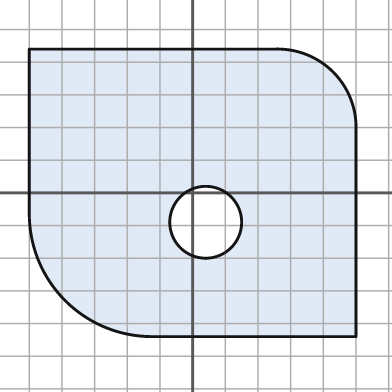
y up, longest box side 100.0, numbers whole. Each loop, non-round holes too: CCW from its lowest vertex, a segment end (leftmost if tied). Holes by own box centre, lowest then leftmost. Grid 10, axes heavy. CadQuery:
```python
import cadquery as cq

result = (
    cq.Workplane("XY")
    .moveTo(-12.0, -44.0)
    .lineTo(50.0, -44.0)
    .lineTo(50.0, 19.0)
    .threePointArc((43.0, 37.0), (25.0, 44.0))
    .lineTo(-50.0, 44.0)
    .lineTo(-50.0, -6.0)
    .threePointArc((-39.0, -33.0), (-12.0, -44.0))
    .close()
    .moveTo(4.0, -9.0)
    .circle(11.0)
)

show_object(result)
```